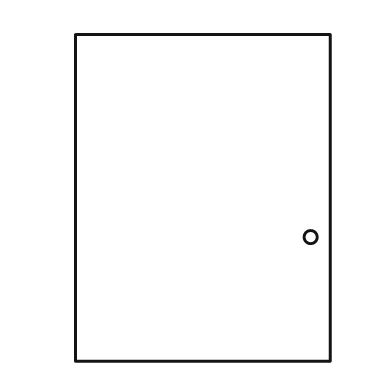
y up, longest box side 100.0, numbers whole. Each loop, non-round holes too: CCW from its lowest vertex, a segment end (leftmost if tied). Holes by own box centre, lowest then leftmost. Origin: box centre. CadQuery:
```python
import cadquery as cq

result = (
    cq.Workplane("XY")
    .moveTo(-39.0, -50.0)
    .lineTo(39.0, -50.0)
    .lineTo(39.0, 50.0)
    .lineTo(-39.0, 50.0)
    .close()
    .moveTo(33.0, -12.0)
    .circle(2.0)
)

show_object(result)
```